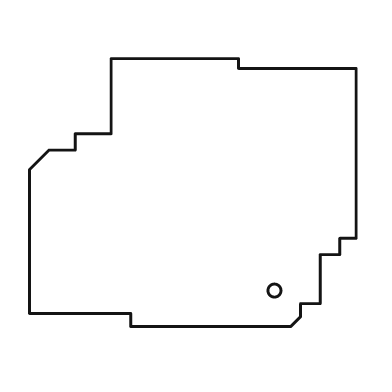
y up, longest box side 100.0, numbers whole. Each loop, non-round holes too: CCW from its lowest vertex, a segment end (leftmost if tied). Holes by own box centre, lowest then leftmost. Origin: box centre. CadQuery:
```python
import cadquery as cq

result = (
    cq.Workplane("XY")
    .moveTo(-19.0, -41.0)
    .lineTo(30.0, -41.0)
    .lineTo(33.0, -38.0)
    .lineTo(33.0, -34.0)
    .lineTo(39.0, -34.0)
    .lineTo(39.0, -19.0)
    .lineTo(45.0, -19.0)
    .lineTo(45.0, -14.0)
    .lineTo(50.0, -14.0)
    .lineTo(50.0, 38.0)
    .lineTo(14.0, 38.0)
    .lineTo(14.0, 41.0)
    .lineTo(-25.0, 41.0)
    .lineTo(-25.0, 18.0)
    .lineTo(-36.0, 18.0)
    .lineTo(-36.0, 13.0)
    .lineTo(-44.0, 13.0)
    .lineTo(-50.0, 7.0)
    .lineTo(-50.0, -37.0)
    .lineTo(-19.0, -37.0)
    .close()
    .moveTo(25.0, -30.0)
    .circle(2.0)
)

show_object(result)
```